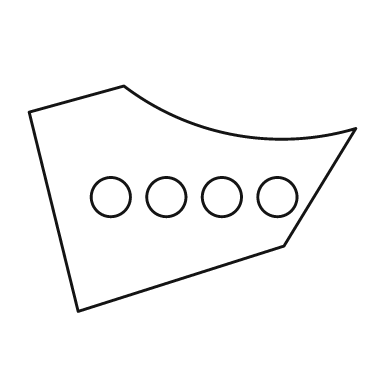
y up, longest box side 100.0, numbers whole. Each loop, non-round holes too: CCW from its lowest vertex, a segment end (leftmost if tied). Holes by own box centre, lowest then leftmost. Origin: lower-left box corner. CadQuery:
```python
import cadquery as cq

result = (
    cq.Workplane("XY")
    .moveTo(15.0, 0.0)
    .lineTo(78.0, 20.0)
    .lineTo(100.0, 56.0)
    .threePointArc((63.0, 54.0), (29.0, 69.0))
    .lineTo(0.0, 61.0)
    .close()
    .moveTo(25.0, 35.0)
    .circle(6.0)
    .moveTo(42.0, 35.0)
    .circle(6.0)
    .moveTo(59.0, 35.0)
    .circle(6.0)
    .moveTo(76.0, 35.0)
    .circle(6.0)
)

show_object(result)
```